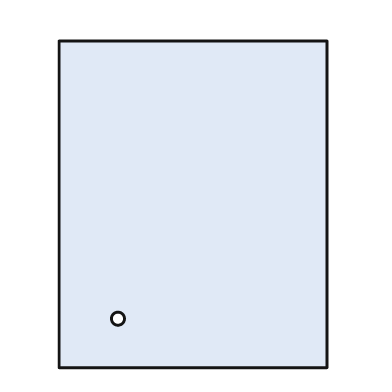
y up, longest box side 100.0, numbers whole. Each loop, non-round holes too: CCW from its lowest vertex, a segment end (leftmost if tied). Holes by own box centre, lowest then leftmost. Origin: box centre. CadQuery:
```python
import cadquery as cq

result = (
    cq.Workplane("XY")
    .moveTo(-41.0, -50.0)
    .lineTo(41.0, -50.0)
    .lineTo(41.0, 50.0)
    .lineTo(-41.0, 50.0)
    .close()
    .moveTo(-23.0, -35.0)
    .circle(2.0)
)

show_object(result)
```